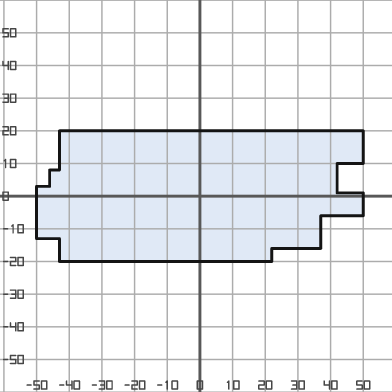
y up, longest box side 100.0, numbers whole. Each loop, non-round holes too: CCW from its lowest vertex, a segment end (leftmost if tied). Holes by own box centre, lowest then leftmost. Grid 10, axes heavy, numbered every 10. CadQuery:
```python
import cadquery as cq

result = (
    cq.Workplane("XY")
    .moveTo(-43.0, -20.0)
    .lineTo(22.0, -20.0)
    .lineTo(22.0, -16.0)
    .lineTo(37.0, -16.0)
    .lineTo(37.0, -6.0)
    .lineTo(50.0, -6.0)
    .lineTo(50.0, 1.0)
    .lineTo(42.0, 1.0)
    .lineTo(42.0, 10.0)
    .lineTo(50.0, 10.0)
    .lineTo(50.0, 20.0)
    .lineTo(-43.0, 20.0)
    .lineTo(-43.0, 8.0)
    .lineTo(-46.0, 8.0)
    .lineTo(-46.0, 3.0)
    .lineTo(-50.0, 3.0)
    .lineTo(-50.0, -13.0)
    .lineTo(-43.0, -13.0)
    .close()
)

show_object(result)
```